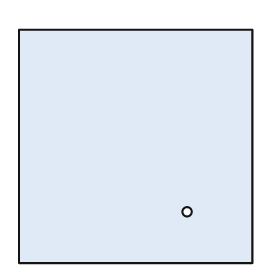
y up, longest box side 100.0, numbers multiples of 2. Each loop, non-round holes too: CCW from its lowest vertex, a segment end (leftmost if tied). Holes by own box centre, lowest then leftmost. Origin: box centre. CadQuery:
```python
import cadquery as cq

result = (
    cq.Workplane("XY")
    .moveTo(-50.0, -50.0)
    .lineTo(50.0, -50.0)
    .lineTo(50.0, 50.0)
    .lineTo(-50.0, 50.0)
    .close()
    .moveTo(22.0, -28.0)
    .circle(2.0)
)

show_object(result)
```